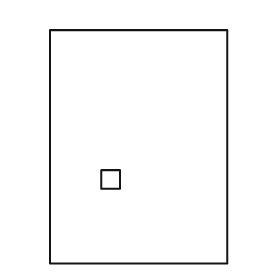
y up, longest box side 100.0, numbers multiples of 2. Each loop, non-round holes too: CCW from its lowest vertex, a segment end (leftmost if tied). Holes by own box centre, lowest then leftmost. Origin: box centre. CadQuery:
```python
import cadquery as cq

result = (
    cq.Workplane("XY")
    .moveTo(-38.0, -50.0)
    .lineTo(38.0, -50.0)
    .lineTo(38.0, 50.0)
    .lineTo(-38.0, 50.0)
    .close()
    .moveTo(-16.0, -18.0)
    .lineTo(-8.0, -18.0)
    .lineTo(-8.0, -10.0)
    .lineTo(-16.0, -10.0)
    .close()
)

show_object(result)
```